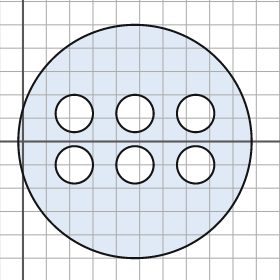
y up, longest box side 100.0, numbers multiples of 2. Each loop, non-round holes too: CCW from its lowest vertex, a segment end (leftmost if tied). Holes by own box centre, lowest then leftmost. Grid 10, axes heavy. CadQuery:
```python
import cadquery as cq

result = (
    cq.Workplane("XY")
    .moveTo(48.0, 0.0)
    .circle(50.0)
    .moveTo(22.0, -10.0)
    .circle(8.0)
    .moveTo(48.0, -10.0)
    .circle(8.0)
    .moveTo(74.0, -10.0)
    .circle(8.0)
    .moveTo(22.0, 12.0)
    .circle(8.0)
    .moveTo(48.0, 12.0)
    .circle(8.0)
    .moveTo(74.0, 12.0)
    .circle(8.0)
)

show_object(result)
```